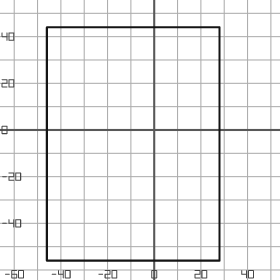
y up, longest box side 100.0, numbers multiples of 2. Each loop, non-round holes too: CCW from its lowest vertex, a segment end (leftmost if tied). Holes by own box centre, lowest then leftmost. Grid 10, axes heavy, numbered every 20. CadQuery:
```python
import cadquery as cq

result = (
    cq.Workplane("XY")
    .moveTo(-46.0, -56.0)
    .lineTo(28.0, -56.0)
    .lineTo(28.0, 44.0)
    .lineTo(-46.0, 44.0)
    .close()
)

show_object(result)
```